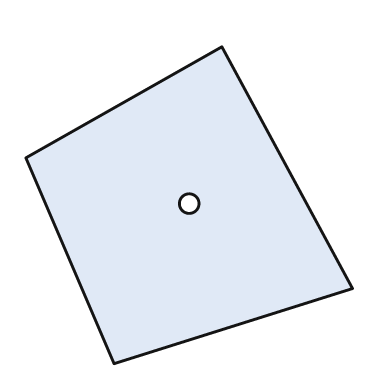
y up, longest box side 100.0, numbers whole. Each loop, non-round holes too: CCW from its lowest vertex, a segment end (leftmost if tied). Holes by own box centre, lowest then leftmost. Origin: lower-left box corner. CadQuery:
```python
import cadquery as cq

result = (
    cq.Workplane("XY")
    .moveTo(27.0, 0.0)
    .lineTo(100.0, 23.0)
    .lineTo(60.0, 97.0)
    .lineTo(0.0, 63.0)
    .close()
    .moveTo(50.0, 49.0)
    .circle(3.0)
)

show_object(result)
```